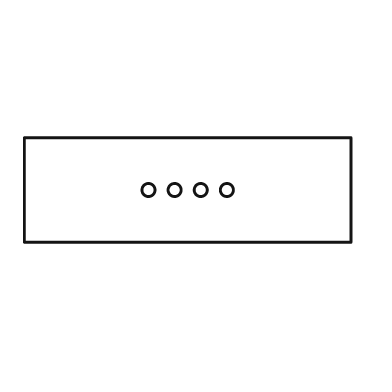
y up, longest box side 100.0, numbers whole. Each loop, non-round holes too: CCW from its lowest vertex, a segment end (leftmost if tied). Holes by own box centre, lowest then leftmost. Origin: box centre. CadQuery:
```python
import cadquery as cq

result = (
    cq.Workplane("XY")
    .moveTo(-50.0, -16.0)
    .lineTo(50.0, -16.0)
    .lineTo(50.0, 16.0)
    .lineTo(-50.0, 16.0)
    .close()
    .moveTo(-12.0, 0.0)
    .circle(2.0)
    .moveTo(-4.0, 0.0)
    .circle(2.0)
    .moveTo(4.0, 0.0)
    .circle(2.0)
    .moveTo(12.0, 0.0)
    .circle(2.0)
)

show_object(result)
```